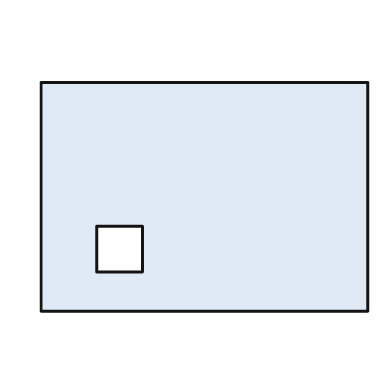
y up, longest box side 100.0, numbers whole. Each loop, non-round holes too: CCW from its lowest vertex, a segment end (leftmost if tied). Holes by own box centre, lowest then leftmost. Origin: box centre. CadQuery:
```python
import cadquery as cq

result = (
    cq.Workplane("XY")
    .moveTo(-50.0, -35.0)
    .lineTo(50.0, -35.0)
    .lineTo(50.0, 35.0)
    .lineTo(-50.0, 35.0)
    .close()
    .moveTo(-33.0, -23.0)
    .lineTo(-19.0, -23.0)
    .lineTo(-19.0, -9.0)
    .lineTo(-33.0, -9.0)
    .close()
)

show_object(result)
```